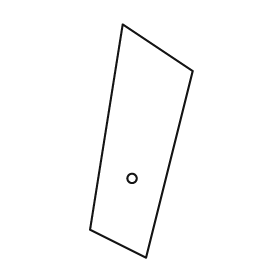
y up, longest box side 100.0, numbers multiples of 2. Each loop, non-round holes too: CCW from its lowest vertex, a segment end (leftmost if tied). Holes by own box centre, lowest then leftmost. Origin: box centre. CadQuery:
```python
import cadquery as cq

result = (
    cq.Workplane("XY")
    .moveTo(2.0, -50.0)
    .lineTo(22.0, 30.0)
    .lineTo(-8.0, 50.0)
    .lineTo(-22.0, -38.0)
    .close()
    .moveTo(-4.0, -16.0)
    .circle(2.0)
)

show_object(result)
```